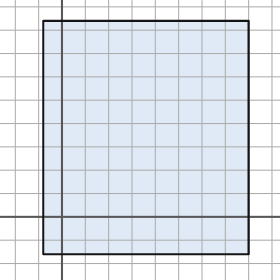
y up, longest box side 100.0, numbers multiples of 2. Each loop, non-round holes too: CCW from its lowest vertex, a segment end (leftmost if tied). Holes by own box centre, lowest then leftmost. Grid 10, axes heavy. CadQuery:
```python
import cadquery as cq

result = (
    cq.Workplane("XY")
    .moveTo(-8.0, -16.0)
    .lineTo(80.0, -16.0)
    .lineTo(80.0, 84.0)
    .lineTo(-8.0, 84.0)
    .close()
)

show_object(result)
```